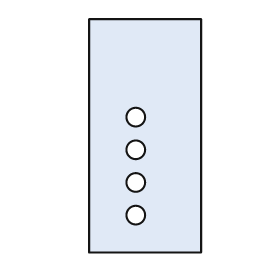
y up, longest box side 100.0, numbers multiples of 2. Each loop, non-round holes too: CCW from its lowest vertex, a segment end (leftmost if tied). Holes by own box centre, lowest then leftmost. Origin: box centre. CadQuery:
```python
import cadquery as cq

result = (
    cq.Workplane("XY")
    .moveTo(-24.0, -50.0)
    .lineTo(24.0, -50.0)
    .lineTo(24.0, 50.0)
    .lineTo(-24.0, 50.0)
    .close()
    .moveTo(-4.0, -34.0)
    .circle(4.0)
    .moveTo(-4.0, -20.0)
    .circle(4.0)
    .moveTo(-4.0, -6.0)
    .circle(4.0)
    .moveTo(-4.0, 8.0)
    .circle(4.0)
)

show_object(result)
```